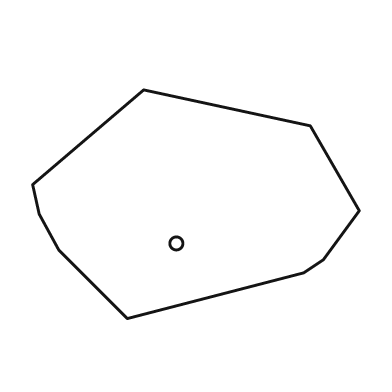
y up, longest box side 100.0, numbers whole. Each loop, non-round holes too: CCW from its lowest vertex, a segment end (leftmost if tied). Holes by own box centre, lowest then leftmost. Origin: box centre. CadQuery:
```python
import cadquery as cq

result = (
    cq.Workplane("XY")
    .moveTo(-21.0, -35.0)
    .lineTo(33.0, -21.0)
    .lineTo(39.0, -17.0)
    .lineTo(50.0, -2.0)
    .lineTo(35.0, 24.0)
    .lineTo(-16.0, 35.0)
    .lineTo(-50.0, 6.0)
    .lineTo(-48.0, -3.0)
    .lineTo(-42.0, -14.0)
    .close()
    .moveTo(-6.0, -12.0)
    .circle(2.0)
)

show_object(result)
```